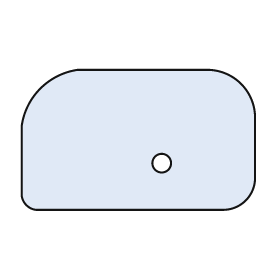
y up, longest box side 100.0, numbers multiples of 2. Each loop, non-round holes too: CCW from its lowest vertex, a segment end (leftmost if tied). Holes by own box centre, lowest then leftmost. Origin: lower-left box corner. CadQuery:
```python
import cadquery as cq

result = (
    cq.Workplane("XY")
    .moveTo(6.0, 0.0)
    .lineTo(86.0, 0.0)
    .threePointArc((96.0, 4.0), (100.0, 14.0))
    .lineTo(100.0, 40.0)
    .threePointArc((94.0, 54.0), (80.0, 60.0))
    .lineTo(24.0, 60.0)
    .threePointArc((8.0, 52.0), (0.0, 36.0))
    .lineTo(0.0, 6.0)
    .threePointArc((2.0, 2.0), (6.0, 0.0))
    .close()
    .moveTo(60.0, 20.0)
    .circle(4.0)
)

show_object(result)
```